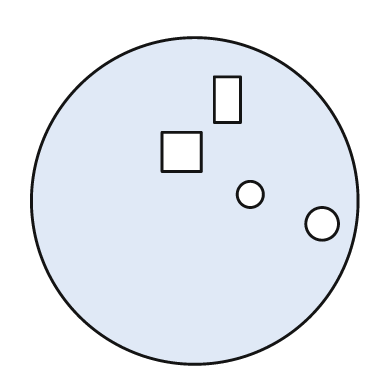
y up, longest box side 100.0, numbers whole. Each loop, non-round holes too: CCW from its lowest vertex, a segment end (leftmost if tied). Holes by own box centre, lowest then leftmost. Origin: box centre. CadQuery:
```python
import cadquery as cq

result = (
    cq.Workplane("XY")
    .moveTo(0.0, 0.0)
    .circle(50.0)
    .moveTo(39.0, -7.0)
    .circle(5.0)
    .moveTo(17.0, 2.0)
    .circle(4.0)
    .moveTo(-10.0, 9.0)
    .lineTo(2.0, 9.0)
    .lineTo(2.0, 21.0)
    .lineTo(-10.0, 21.0)
    .close()
    .moveTo(6.0, 24.0)
    .lineTo(14.0, 24.0)
    .lineTo(14.0, 38.0)
    .lineTo(6.0, 38.0)
    .close()
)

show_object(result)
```